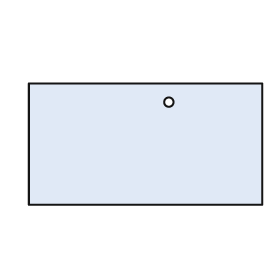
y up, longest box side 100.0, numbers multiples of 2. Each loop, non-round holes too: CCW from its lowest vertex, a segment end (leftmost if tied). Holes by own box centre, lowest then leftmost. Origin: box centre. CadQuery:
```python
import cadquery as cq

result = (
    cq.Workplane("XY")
    .moveTo(-50.0, -26.0)
    .lineTo(50.0, -26.0)
    .lineTo(50.0, 26.0)
    .lineTo(-50.0, 26.0)
    .close()
    .moveTo(10.0, 18.0)
    .circle(2.0)
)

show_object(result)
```